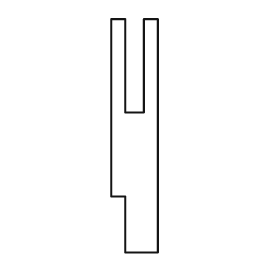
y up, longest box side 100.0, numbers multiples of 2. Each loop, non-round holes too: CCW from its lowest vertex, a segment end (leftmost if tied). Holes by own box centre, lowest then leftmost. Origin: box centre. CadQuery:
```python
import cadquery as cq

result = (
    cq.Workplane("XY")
    .moveTo(-4.0, -50.0)
    .lineTo(10.0, -50.0)
    .lineTo(10.0, 50.0)
    .lineTo(4.0, 50.0)
    .lineTo(4.0, 10.0)
    .lineTo(-4.0, 10.0)
    .lineTo(-4.0, 50.0)
    .lineTo(-10.0, 50.0)
    .lineTo(-10.0, -26.0)
    .lineTo(-4.0, -26.0)
    .close()
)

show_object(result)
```